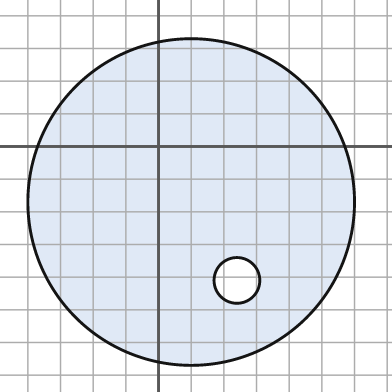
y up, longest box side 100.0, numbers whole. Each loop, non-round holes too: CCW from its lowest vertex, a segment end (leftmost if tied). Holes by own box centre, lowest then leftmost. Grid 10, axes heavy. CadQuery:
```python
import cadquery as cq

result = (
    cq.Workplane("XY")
    .moveTo(10.0, -17.0)
    .circle(50.0)
    .moveTo(24.0, -41.0)
    .circle(7.0)
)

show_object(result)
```